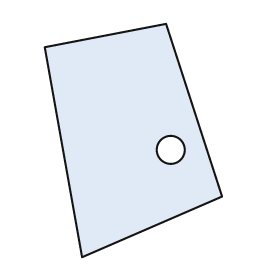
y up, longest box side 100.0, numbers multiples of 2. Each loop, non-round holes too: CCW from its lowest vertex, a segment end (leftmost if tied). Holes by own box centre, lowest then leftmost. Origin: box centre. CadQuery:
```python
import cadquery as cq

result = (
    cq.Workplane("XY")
    .moveTo(-22.0, -50.0)
    .lineTo(38.0, -24.0)
    .lineTo(14.0, 50.0)
    .lineTo(-38.0, 40.0)
    .close()
    .moveTo(16.0, -4.0)
    .circle(6.0)
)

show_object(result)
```